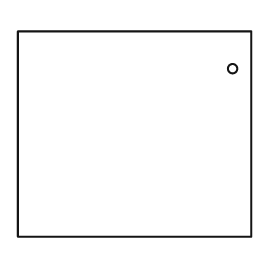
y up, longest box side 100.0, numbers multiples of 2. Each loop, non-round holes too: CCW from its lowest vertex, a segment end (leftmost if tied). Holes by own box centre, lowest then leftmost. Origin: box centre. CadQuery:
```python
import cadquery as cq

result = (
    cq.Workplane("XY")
    .moveTo(-50.0, -44.0)
    .lineTo(50.0, -44.0)
    .lineTo(50.0, 44.0)
    .lineTo(-50.0, 44.0)
    .close()
    .moveTo(42.0, 28.0)
    .circle(2.0)
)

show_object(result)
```